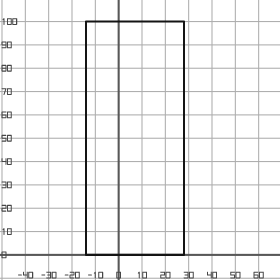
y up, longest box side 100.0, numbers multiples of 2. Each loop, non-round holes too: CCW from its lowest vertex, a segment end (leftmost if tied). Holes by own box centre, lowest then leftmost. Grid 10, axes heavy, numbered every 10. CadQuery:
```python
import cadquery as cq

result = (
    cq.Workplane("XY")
    .moveTo(-14.0, 0.0)
    .lineTo(28.0, 0.0)
    .lineTo(28.0, 100.0)
    .lineTo(-14.0, 100.0)
    .close()
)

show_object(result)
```